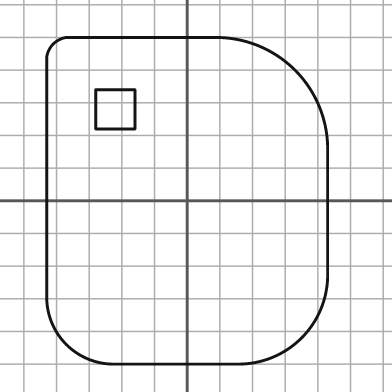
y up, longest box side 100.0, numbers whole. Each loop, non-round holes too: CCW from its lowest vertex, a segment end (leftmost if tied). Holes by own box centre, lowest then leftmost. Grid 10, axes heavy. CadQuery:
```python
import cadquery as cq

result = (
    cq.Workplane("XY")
    .moveTo(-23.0, -50.0)
    .lineTo(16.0, -50.0)
    .threePointArc((35.0, -42.0), (43.0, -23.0))
    .lineTo(43.0, 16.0)
    .threePointArc((33.0, 40.0), (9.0, 50.0))
    .lineTo(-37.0, 50.0)
    .threePointArc((-41.0, 48.0), (-43.0, 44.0))
    .lineTo(-43.0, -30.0)
    .threePointArc((-37.0, -44.0), (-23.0, -50.0))
    .close()
    .moveTo(-28.0, 22.0)
    .lineTo(-16.0, 22.0)
    .lineTo(-16.0, 34.0)
    .lineTo(-28.0, 34.0)
    .close()
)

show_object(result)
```